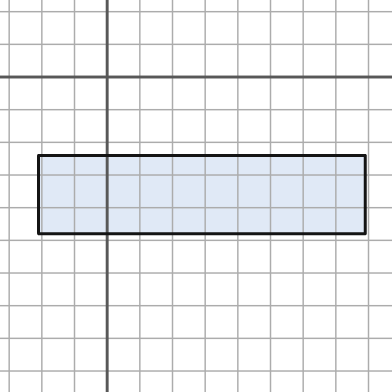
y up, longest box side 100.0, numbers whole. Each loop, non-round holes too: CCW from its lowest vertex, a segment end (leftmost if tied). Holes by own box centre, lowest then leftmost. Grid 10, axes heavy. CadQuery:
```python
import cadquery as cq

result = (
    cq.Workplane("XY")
    .moveTo(-21.0, -48.0)
    .lineTo(79.0, -48.0)
    .lineTo(79.0, -24.0)
    .lineTo(-21.0, -24.0)
    .close()
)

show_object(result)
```